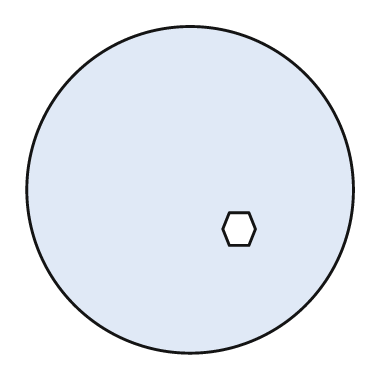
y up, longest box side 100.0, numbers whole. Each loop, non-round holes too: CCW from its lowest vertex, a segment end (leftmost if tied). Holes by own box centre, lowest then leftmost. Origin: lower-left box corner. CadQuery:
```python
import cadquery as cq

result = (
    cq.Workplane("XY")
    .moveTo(50.0, 50.0)
    .circle(50.0)
    .moveTo(62.0, 33.0)
    .lineTo(68.0, 33.0)
    .lineTo(70.0, 38.0)
    .lineTo(68.0, 43.0)
    .lineTo(62.0, 43.0)
    .lineTo(60.0, 38.0)
    .close()
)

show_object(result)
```